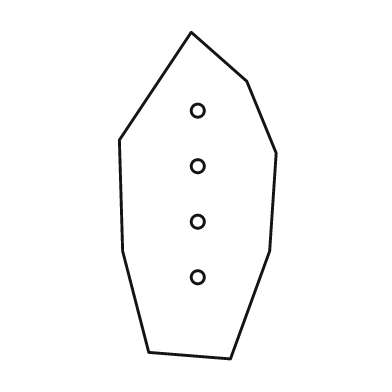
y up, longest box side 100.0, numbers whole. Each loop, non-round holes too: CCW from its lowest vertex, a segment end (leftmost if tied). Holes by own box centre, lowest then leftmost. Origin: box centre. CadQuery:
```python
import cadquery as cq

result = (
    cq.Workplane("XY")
    .moveTo(10.0, -50.0)
    .lineTo(22.0, -17.0)
    .lineTo(24.0, 13.0)
    .lineTo(15.0, 35.0)
    .lineTo(-2.0, 50.0)
    .lineTo(-24.0, 17.0)
    .lineTo(-23.0, -17.0)
    .lineTo(-15.0, -48.0)
    .close()
    .moveTo(0.0, -25.0)
    .circle(2.0)
    .moveTo(0.0, -8.0)
    .circle(2.0)
    .moveTo(0.0, 9.0)
    .circle(2.0)
    .moveTo(0.0, 26.0)
    .circle(2.0)
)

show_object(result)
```